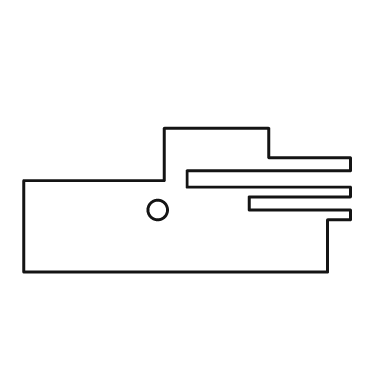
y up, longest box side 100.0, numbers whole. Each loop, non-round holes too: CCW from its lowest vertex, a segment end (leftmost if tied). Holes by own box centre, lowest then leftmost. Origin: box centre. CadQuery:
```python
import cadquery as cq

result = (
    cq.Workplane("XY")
    .moveTo(-50.0, -22.0)
    .lineTo(43.0, -22.0)
    .lineTo(43.0, -6.0)
    .lineTo(50.0, -6.0)
    .lineTo(50.0, -3.0)
    .lineTo(19.0, -3.0)
    .lineTo(19.0, 1.0)
    .lineTo(50.0, 1.0)
    .lineTo(50.0, 4.0)
    .lineTo(0.0, 4.0)
    .lineTo(0.0, 9.0)
    .lineTo(50.0, 9.0)
    .lineTo(50.0, 13.0)
    .lineTo(25.0, 13.0)
    .lineTo(25.0, 22.0)
    .lineTo(-7.0, 22.0)
    .lineTo(-7.0, 6.0)
    .lineTo(-50.0, 6.0)
    .close()
    .moveTo(-9.0, -3.0)
    .circle(3.0)
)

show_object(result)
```